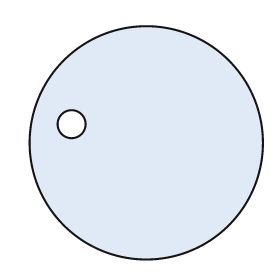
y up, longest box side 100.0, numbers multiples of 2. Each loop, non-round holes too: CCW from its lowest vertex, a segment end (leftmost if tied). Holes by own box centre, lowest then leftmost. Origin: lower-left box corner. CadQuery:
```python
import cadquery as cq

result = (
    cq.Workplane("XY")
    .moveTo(50.0, 50.0)
    .circle(50.0)
    .moveTo(18.0, 58.0)
    .circle(6.0)
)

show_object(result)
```